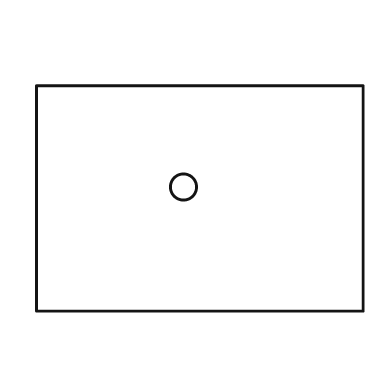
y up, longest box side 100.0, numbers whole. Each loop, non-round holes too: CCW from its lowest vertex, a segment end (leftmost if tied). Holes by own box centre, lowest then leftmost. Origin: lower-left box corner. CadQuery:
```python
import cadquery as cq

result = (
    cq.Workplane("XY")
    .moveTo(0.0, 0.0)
    .lineTo(100.0, 0.0)
    .lineTo(100.0, 69.0)
    .lineTo(0.0, 69.0)
    .close()
    .moveTo(45.0, 38.0)
    .circle(4.0)
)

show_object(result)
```